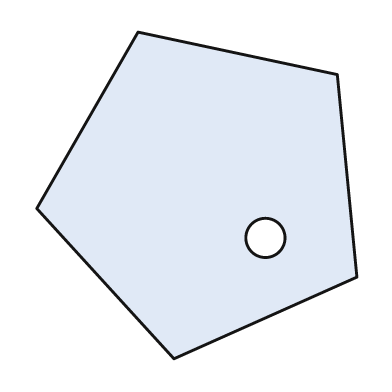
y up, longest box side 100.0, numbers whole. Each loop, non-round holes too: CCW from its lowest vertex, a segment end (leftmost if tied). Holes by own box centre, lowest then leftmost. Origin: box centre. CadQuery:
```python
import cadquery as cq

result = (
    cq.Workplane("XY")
    .moveTo(-7.0, -50.0)
    .lineTo(49.0, -25.0)
    .lineTo(43.0, 37.0)
    .lineTo(-18.0, 50.0)
    .lineTo(-49.0, -4.0)
    .close()
    .moveTo(21.0, -13.0)
    .circle(6.0)
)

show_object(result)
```